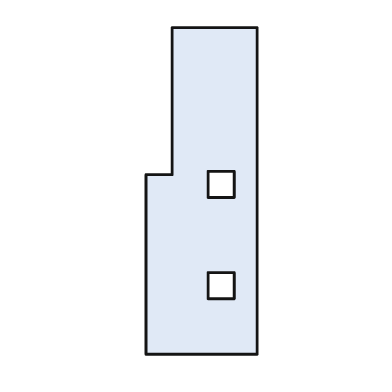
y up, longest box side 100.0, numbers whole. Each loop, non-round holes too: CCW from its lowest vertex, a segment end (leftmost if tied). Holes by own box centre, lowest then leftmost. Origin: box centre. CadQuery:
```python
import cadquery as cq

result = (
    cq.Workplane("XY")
    .moveTo(-17.0, -50.0)
    .lineTo(17.0, -50.0)
    .lineTo(17.0, 50.0)
    .lineTo(-9.0, 50.0)
    .lineTo(-9.0, 5.0)
    .lineTo(-17.0, 5.0)
    .close()
    .moveTo(2.0, -33.0)
    .lineTo(10.0, -33.0)
    .lineTo(10.0, -25.0)
    .lineTo(2.0, -25.0)
    .close()
    .moveTo(2.0, -2.0)
    .lineTo(10.0, -2.0)
    .lineTo(10.0, 6.0)
    .lineTo(2.0, 6.0)
    .close()
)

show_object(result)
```